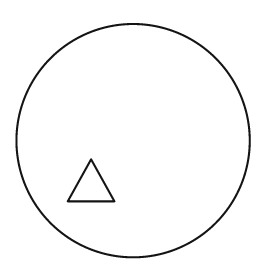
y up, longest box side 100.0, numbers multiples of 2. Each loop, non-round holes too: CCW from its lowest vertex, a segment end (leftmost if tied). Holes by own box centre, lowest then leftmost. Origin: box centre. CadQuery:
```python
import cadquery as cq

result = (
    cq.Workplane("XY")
    .moveTo(0.0, 0.0)
    .circle(50.0)
    .moveTo(-28.0, -26.0)
    .lineTo(-8.0, -26.0)
    .lineTo(-18.0, -8.0)
    .close()
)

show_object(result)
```